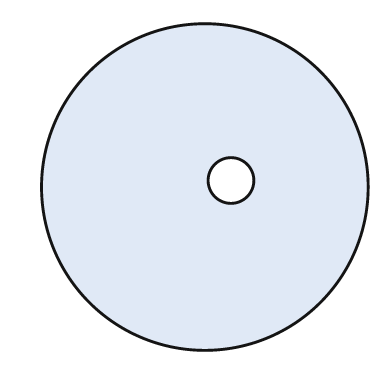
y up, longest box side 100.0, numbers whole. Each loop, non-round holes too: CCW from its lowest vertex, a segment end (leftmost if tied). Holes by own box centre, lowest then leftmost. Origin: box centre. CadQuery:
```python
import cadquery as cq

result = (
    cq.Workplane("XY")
    .moveTo(0.0, 0.0)
    .circle(50.0)
    .moveTo(8.0, 2.0)
    .circle(7.0)
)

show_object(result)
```